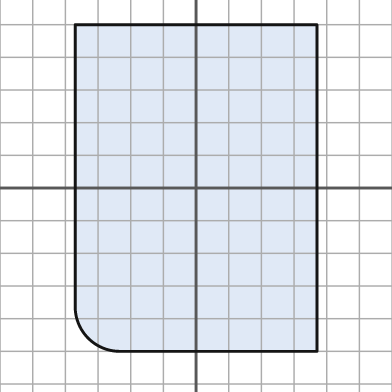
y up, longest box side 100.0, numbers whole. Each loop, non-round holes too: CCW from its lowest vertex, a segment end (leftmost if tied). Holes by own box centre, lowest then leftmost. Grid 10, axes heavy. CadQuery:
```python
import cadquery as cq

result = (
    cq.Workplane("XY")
    .moveTo(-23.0, -50.0)
    .lineTo(37.0, -50.0)
    .lineTo(37.0, 50.0)
    .lineTo(-37.0, 50.0)
    .lineTo(-37.0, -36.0)
    .threePointArc((-33.0, -46.0), (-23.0, -50.0))
    .close()
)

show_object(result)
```